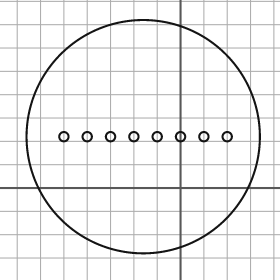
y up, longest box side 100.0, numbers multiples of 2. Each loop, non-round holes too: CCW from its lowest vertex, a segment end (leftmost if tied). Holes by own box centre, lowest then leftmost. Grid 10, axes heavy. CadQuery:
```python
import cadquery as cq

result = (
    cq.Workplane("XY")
    .moveTo(-16.0, 22.0)
    .circle(50.0)
    .moveTo(-50.0, 22.0)
    .circle(2.0)
    .moveTo(-40.0, 22.0)
    .circle(2.0)
    .moveTo(-30.0, 22.0)
    .circle(2.0)
    .moveTo(-20.0, 22.0)
    .circle(2.0)
    .moveTo(-10.0, 22.0)
    .circle(2.0)
    .moveTo(0.0, 22.0)
    .circle(2.0)
    .moveTo(10.0, 22.0)
    .circle(2.0)
    .moveTo(20.0, 22.0)
    .circle(2.0)
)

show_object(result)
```